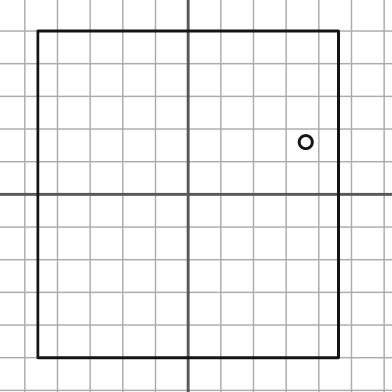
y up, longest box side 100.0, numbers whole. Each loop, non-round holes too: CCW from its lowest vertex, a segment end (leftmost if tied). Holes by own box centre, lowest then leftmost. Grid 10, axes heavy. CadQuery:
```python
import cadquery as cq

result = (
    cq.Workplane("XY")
    .moveTo(-46.0, -50.0)
    .lineTo(46.0, -50.0)
    .lineTo(46.0, 50.0)
    .lineTo(-46.0, 50.0)
    .close()
    .moveTo(36.0, 16.0)
    .circle(2.0)
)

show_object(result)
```